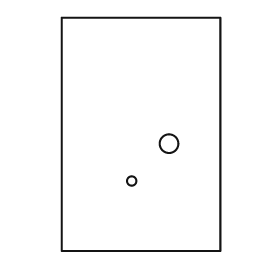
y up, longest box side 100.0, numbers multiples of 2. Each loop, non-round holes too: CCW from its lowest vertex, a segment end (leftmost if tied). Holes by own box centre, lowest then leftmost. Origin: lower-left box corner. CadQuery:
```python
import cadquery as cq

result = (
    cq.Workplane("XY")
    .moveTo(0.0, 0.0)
    .lineTo(68.0, 0.0)
    .lineTo(68.0, 100.0)
    .lineTo(0.0, 100.0)
    .close()
    .moveTo(30.0, 30.0)
    .circle(2.0)
    .moveTo(46.0, 46.0)
    .circle(4.0)
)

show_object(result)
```